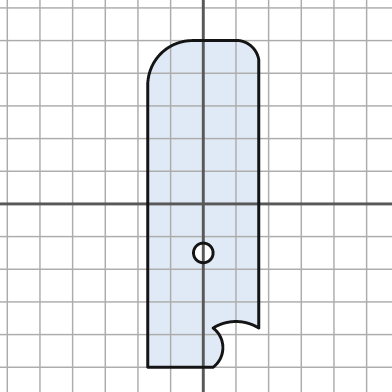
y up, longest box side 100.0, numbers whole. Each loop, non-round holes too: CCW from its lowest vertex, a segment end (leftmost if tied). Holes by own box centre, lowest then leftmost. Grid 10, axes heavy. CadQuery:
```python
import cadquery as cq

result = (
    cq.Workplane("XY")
    .moveTo(-17.0, -50.0)
    .lineTo(3.0, -50.0)
    .threePointArc((6.0, -44.0), (3.0, -38.0))
    .threePointArc((10.0, -36.0), (17.0, -38.0))
    .lineTo(17.0, 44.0)
    .threePointArc((15.0, 48.0), (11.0, 50.0))
    .lineTo(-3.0, 50.0)
    .threePointArc((-13.0, 46.0), (-17.0, 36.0))
    .close()
    .moveTo(0.0, -15.0)
    .circle(3.0)
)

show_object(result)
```